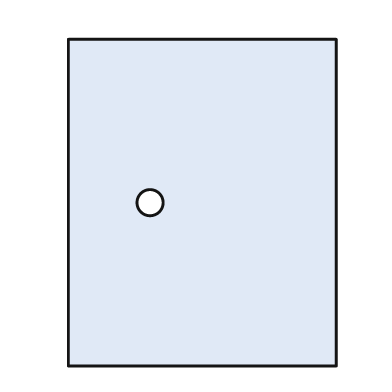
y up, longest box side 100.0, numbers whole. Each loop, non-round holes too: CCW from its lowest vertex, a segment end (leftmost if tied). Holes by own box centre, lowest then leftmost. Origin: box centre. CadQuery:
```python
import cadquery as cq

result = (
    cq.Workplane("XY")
    .moveTo(-41.0, -50.0)
    .lineTo(41.0, -50.0)
    .lineTo(41.0, 50.0)
    .lineTo(-41.0, 50.0)
    .close()
    .moveTo(-16.0, 0.0)
    .circle(4.0)
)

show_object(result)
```